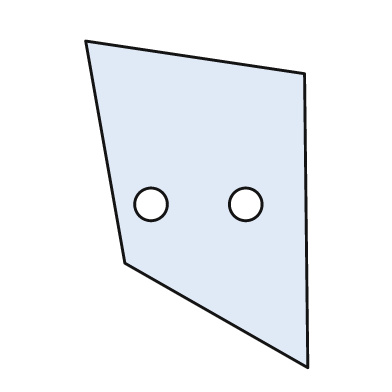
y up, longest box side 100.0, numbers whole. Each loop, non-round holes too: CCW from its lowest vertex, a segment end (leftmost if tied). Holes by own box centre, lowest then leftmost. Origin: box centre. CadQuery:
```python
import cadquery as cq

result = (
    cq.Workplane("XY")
    .moveTo(34.0, -50.0)
    .lineTo(33.0, 40.0)
    .lineTo(-34.0, 50.0)
    .lineTo(-22.0, -18.0)
    .close()
    .moveTo(-14.0, 0.0)
    .circle(5.0)
    .moveTo(15.0, 0.0)
    .circle(5.0)
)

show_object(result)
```